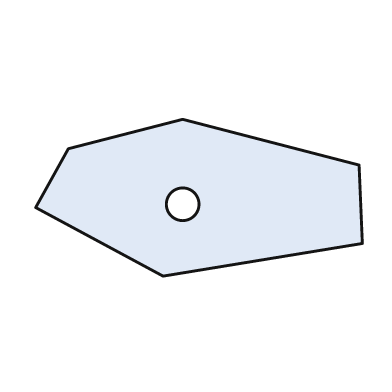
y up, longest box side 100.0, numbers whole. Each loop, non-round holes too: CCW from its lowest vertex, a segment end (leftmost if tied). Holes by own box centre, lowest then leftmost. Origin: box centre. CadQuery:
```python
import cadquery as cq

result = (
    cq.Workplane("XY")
    .moveTo(-11.0, -24.0)
    .lineTo(50.0, -14.0)
    .lineTo(49.0, 10.0)
    .lineTo(-5.0, 24.0)
    .lineTo(-40.0, 15.0)
    .lineTo(-50.0, -3.0)
    .close()
    .moveTo(-5.0, -2.0)
    .circle(5.0)
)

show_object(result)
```